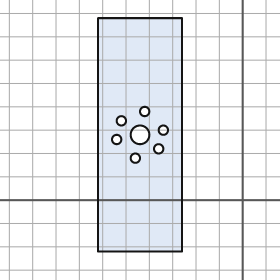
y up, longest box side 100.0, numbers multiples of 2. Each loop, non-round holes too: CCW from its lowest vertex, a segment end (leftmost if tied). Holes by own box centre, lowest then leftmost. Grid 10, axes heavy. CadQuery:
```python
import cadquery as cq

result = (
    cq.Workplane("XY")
    .moveTo(-62.0, -22.0)
    .lineTo(-26.0, -22.0)
    .lineTo(-26.0, 78.0)
    .lineTo(-62.0, 78.0)
    .close()
    .moveTo(-46.0, 18.0)
    .circle(2.0)
    .moveTo(-36.0, 22.0)
    .circle(2.0)
    .moveTo(-54.0, 26.0)
    .circle(2.0)
    .moveTo(-44.0, 28.0)
    .circle(4.0)
    .moveTo(-34.0, 30.0)
    .circle(2.0)
    .moveTo(-52.0, 34.0)
    .circle(2.0)
    .moveTo(-42.0, 38.0)
    .circle(2.0)
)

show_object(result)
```